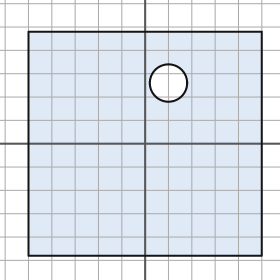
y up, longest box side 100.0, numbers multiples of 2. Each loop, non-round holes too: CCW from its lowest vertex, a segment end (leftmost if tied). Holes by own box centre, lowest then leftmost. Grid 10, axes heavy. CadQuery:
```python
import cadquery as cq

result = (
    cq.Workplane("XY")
    .moveTo(-50.0, -48.0)
    .lineTo(50.0, -48.0)
    .lineTo(50.0, 48.0)
    .lineTo(-50.0, 48.0)
    .close()
    .moveTo(10.0, 26.0)
    .circle(8.0)
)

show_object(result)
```